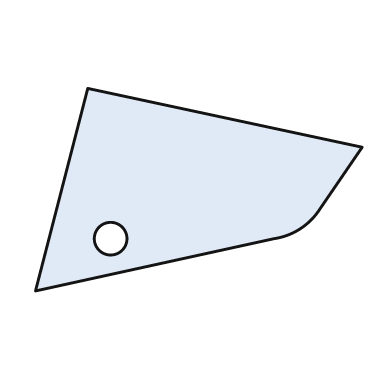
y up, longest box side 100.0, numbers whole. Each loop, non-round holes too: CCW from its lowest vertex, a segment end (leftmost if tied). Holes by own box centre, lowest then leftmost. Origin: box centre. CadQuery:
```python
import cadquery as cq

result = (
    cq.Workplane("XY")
    .moveTo(-50.0, -31.0)
    .lineTo(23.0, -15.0)
    .threePointArc((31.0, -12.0), (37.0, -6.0))
    .lineTo(50.0, 13.0)
    .lineTo(-34.0, 31.0)
    .close()
    .moveTo(-27.0, -15.0)
    .circle(5.0)
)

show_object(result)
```